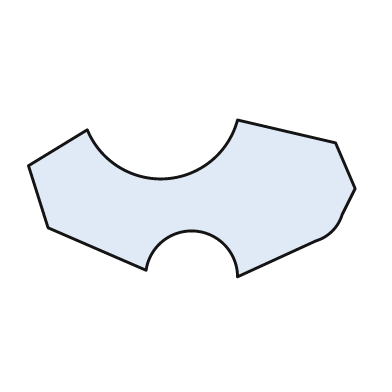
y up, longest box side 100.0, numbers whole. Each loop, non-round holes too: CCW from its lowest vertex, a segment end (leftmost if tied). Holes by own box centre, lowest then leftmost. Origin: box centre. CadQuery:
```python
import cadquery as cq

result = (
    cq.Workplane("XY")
    .moveTo(14.0, -24.0)
    .lineTo(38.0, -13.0)
    .threePointArc((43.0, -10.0), (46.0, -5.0))
    .lineTo(50.0, 3.0)
    .lineTo(44.0, 17.0)
    .lineTo(14.0, 24.0)
    .threePointArc((-8.0, 6.0), (-32.0, 21.0))
    .lineTo(-50.0, 10.0)
    .lineTo(-44.0, -9.0)
    .lineTo(-14.0, -22.0)
    .threePointArc((1.0, -10.0), (14.0, -24.0))
    .close()
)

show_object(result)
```